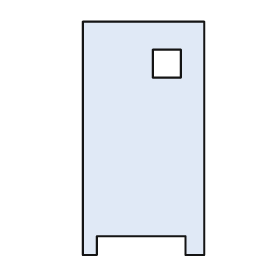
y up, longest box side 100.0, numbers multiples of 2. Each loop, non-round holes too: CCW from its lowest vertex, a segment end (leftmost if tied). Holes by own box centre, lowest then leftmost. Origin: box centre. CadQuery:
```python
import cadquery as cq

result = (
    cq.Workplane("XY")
    .moveTo(-26.0, -50.0)
    .lineTo(-20.0, -50.0)
    .lineTo(-20.0, -42.0)
    .lineTo(18.0, -42.0)
    .lineTo(18.0, -50.0)
    .lineTo(26.0, -50.0)
    .lineTo(26.0, 50.0)
    .lineTo(-26.0, 50.0)
    .close()
    .moveTo(4.0, 26.0)
    .lineTo(16.0, 26.0)
    .lineTo(16.0, 38.0)
    .lineTo(4.0, 38.0)
    .close()
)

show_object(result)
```